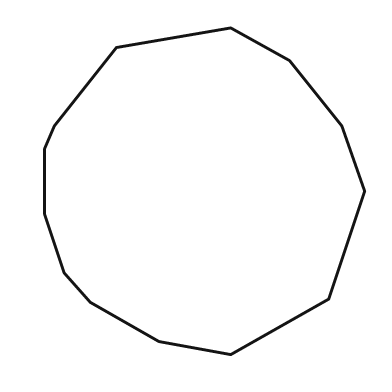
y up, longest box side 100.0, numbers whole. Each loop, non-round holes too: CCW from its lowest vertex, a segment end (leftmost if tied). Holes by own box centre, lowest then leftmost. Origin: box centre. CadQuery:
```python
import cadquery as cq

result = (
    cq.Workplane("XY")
    .moveTo(8.0, -50.0)
    .lineTo(38.0, -33.0)
    .lineTo(49.0, 0.0)
    .lineTo(42.0, 20.0)
    .lineTo(26.0, 40.0)
    .lineTo(8.0, 50.0)
    .lineTo(-27.0, 44.0)
    .lineTo(-46.0, 20.0)
    .lineTo(-49.0, 13.0)
    .lineTo(-49.0, -7.0)
    .lineTo(-43.0, -25.0)
    .lineTo(-35.0, -34.0)
    .lineTo(-14.0, -46.0)
    .close()
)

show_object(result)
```